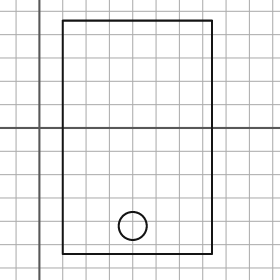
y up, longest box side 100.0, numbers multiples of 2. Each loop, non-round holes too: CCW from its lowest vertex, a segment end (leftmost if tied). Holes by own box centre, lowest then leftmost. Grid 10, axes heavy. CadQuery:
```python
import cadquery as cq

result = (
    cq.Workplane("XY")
    .moveTo(10.0, -54.0)
    .lineTo(74.0, -54.0)
    .lineTo(74.0, 46.0)
    .lineTo(10.0, 46.0)
    .close()
    .moveTo(40.0, -42.0)
    .circle(6.0)
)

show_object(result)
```